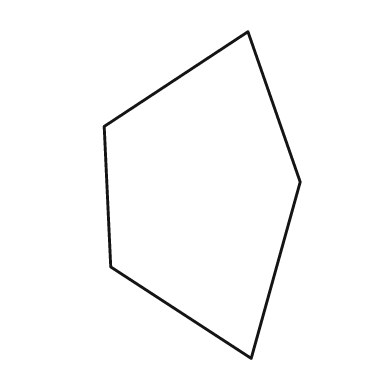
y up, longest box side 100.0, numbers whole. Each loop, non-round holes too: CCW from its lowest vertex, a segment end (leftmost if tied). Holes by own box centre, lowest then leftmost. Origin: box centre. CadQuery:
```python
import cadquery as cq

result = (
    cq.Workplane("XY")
    .moveTo(15.0, -50.0)
    .lineTo(30.0, 4.0)
    .lineTo(14.0, 50.0)
    .lineTo(-30.0, 21.0)
    .lineTo(-28.0, -22.0)
    .close()
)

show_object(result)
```